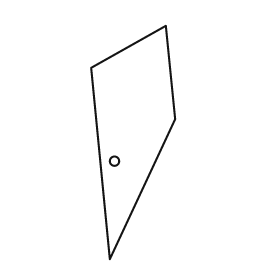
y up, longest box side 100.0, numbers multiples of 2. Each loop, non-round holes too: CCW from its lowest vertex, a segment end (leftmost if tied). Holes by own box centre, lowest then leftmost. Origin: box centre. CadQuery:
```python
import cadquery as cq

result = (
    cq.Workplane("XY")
    .moveTo(-10.0, -50.0)
    .lineTo(18.0, 10.0)
    .lineTo(14.0, 50.0)
    .lineTo(-18.0, 32.0)
    .close()
    .moveTo(-8.0, -8.0)
    .circle(2.0)
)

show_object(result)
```